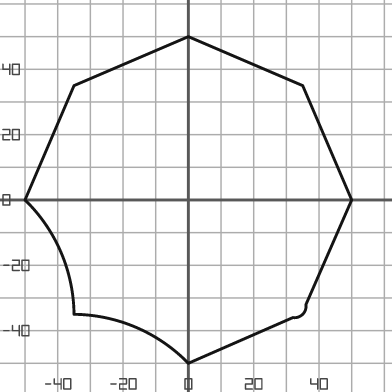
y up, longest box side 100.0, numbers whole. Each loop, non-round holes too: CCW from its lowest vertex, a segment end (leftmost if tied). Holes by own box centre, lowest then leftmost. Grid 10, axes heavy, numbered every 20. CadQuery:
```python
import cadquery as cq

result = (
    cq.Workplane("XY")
    .moveTo(0.0, -50.0)
    .lineTo(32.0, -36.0)
    .threePointArc((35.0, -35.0), (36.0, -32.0))
    .lineTo(50.0, 0.0)
    .lineTo(35.0, 35.0)
    .lineTo(0.0, 50.0)
    .lineTo(-35.0, 35.0)
    .lineTo(-50.0, 0.0)
    .threePointArc((-39.0, -16.0), (-35.0, -35.0))
    .threePointArc((-16.0, -39.0), (0.0, -50.0))
    .close()
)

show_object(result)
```